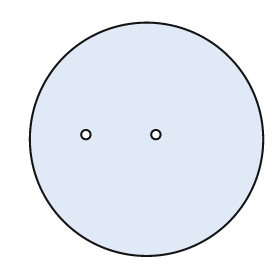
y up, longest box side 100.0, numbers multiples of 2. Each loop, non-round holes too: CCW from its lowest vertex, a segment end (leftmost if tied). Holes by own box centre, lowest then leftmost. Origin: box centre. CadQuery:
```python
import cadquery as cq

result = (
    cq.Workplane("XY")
    .moveTo(0.0, 0.0)
    .circle(50.0)
    .moveTo(-26.0, 2.0)
    .circle(2.0)
    .moveTo(4.0, 2.0)
    .circle(2.0)
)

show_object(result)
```